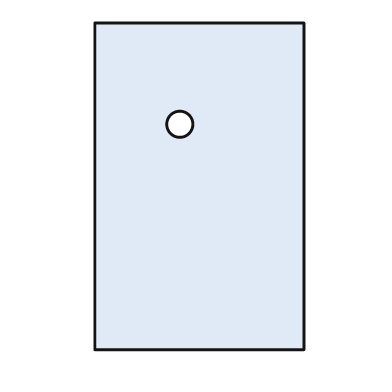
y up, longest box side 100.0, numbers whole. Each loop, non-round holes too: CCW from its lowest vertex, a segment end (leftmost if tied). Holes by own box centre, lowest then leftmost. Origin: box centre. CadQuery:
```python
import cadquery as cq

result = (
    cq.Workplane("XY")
    .moveTo(-32.0, -50.0)
    .lineTo(32.0, -50.0)
    .lineTo(32.0, 50.0)
    .lineTo(-32.0, 50.0)
    .close()
    .moveTo(-6.0, 19.0)
    .circle(4.0)
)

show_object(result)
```